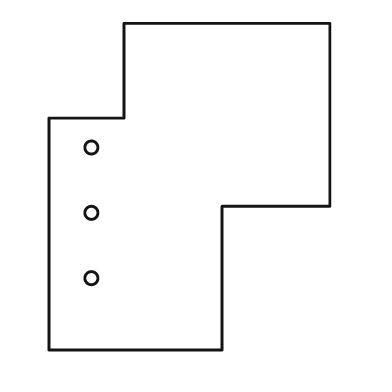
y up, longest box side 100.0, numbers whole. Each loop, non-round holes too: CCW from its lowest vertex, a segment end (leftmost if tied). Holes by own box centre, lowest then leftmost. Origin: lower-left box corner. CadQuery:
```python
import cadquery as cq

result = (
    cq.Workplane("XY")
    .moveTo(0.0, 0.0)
    .lineTo(53.0, 0.0)
    .lineTo(53.0, 44.0)
    .lineTo(86.0, 44.0)
    .lineTo(86.0, 100.0)
    .lineTo(23.0, 100.0)
    .lineTo(23.0, 71.0)
    .lineTo(0.0, 71.0)
    .close()
    .moveTo(13.0, 22.0)
    .circle(2.0)
    .moveTo(13.0, 42.0)
    .circle(2.0)
    .moveTo(13.0, 62.0)
    .circle(2.0)
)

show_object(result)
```